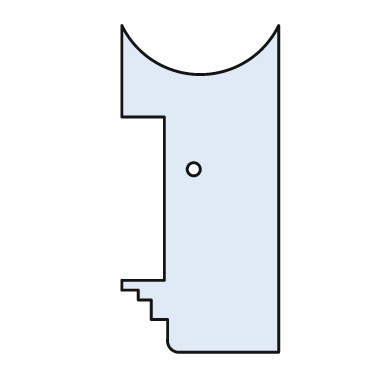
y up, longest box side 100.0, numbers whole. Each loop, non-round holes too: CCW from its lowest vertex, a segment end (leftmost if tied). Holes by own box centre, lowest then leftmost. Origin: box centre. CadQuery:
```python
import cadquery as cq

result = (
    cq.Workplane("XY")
    .moveTo(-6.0, -50.0)
    .lineTo(24.0, -50.0)
    .lineTo(24.0, 50.0)
    .threePointArc((0.0, 35.0), (-24.0, 50.0))
    .lineTo(-24.0, 22.0)
    .lineTo(-11.0, 22.0)
    .lineTo(-11.0, -28.0)
    .lineTo(-24.0, -28.0)
    .lineTo(-24.0, -31.0)
    .lineTo(-19.0, -31.0)
    .lineTo(-19.0, -34.0)
    .lineTo(-15.0, -34.0)
    .lineTo(-15.0, -40.0)
    .lineTo(-10.0, -40.0)
    .lineTo(-10.0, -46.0)
    .threePointArc((-9.0, -49.0), (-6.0, -50.0))
    .close()
    .moveTo(-2.0, 6.0)
    .circle(2.0)
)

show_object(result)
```